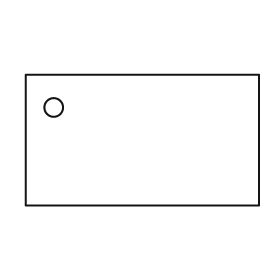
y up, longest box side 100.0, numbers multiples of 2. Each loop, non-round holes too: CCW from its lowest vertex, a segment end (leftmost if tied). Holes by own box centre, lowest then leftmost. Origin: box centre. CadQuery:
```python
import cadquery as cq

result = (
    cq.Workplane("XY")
    .moveTo(-50.0, -28.0)
    .lineTo(50.0, -28.0)
    .lineTo(50.0, 28.0)
    .lineTo(-50.0, 28.0)
    .close()
    .moveTo(-38.0, 14.0)
    .circle(4.0)
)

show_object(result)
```